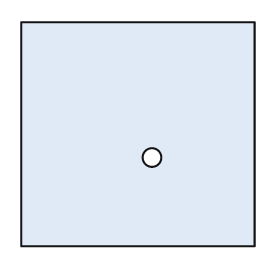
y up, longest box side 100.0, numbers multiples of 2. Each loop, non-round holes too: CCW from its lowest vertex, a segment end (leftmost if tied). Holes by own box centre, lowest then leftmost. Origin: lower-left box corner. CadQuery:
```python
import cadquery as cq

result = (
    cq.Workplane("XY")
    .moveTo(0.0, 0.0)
    .lineTo(100.0, 0.0)
    .lineTo(100.0, 96.0)
    .lineTo(0.0, 96.0)
    .close()
    .moveTo(56.0, 38.0)
    .circle(4.0)
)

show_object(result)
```